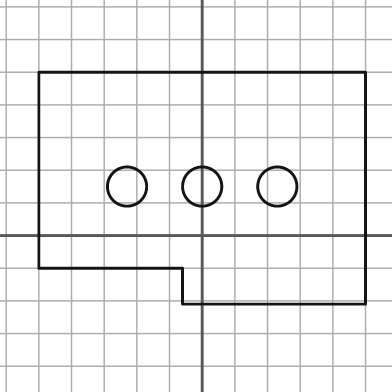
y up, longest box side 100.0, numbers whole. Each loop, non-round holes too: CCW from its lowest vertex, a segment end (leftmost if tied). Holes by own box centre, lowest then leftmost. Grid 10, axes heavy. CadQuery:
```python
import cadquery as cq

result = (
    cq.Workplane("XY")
    .moveTo(-6.0, -21.0)
    .lineTo(50.0, -21.0)
    .lineTo(50.0, 50.0)
    .lineTo(-50.0, 50.0)
    .lineTo(-50.0, -10.0)
    .lineTo(-6.0, -10.0)
    .close()
    .moveTo(-23.0, 15.0)
    .circle(6.0)
    .moveTo(0.0, 15.0)
    .circle(6.0)
    .moveTo(23.0, 15.0)
    .circle(6.0)
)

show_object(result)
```